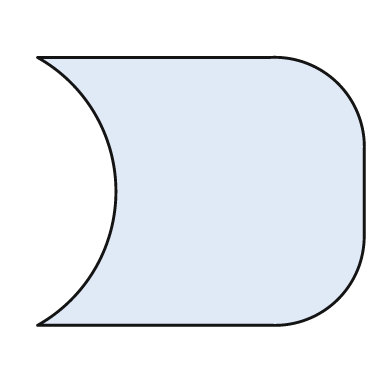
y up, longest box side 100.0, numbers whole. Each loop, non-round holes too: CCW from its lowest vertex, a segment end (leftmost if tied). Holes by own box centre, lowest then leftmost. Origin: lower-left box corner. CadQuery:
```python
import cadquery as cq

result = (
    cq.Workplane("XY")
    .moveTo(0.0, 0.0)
    .lineTo(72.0, 0.0)
    .threePointArc((92.0, 8.0), (100.0, 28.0))
    .lineTo(100.0, 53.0)
    .threePointArc((92.0, 74.0), (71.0, 82.0))
    .lineTo(0.0, 82.0)
    .threePointArc((24.0, 41.0), (0.0, 0.0))
    .close()
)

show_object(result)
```